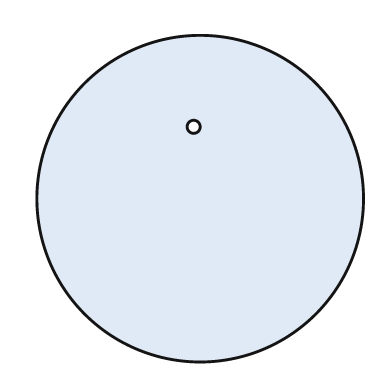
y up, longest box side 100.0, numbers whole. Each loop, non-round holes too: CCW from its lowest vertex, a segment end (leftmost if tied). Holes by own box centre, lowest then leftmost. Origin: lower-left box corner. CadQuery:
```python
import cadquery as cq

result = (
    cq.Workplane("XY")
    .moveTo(50.0, 50.0)
    .circle(50.0)
    .moveTo(48.0, 72.0)
    .circle(2.0)
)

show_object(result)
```